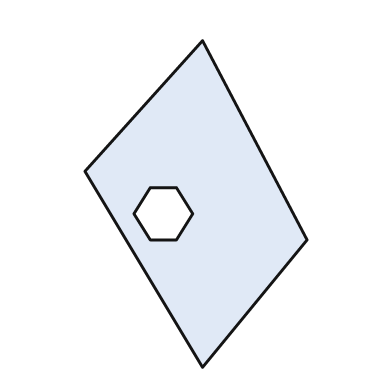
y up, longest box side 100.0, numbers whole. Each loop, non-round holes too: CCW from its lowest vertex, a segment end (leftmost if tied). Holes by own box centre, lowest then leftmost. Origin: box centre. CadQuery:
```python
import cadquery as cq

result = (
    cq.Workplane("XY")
    .moveTo(2.0, -50.0)
    .lineTo(34.0, -11.0)
    .lineTo(2.0, 50.0)
    .lineTo(-34.0, 10.0)
    .close()
    .moveTo(-14.0, -11.0)
    .lineTo(-6.0, -11.0)
    .lineTo(-1.0, -3.0)
    .lineTo(-6.0, 5.0)
    .lineTo(-14.0, 5.0)
    .lineTo(-19.0, -3.0)
    .close()
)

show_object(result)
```